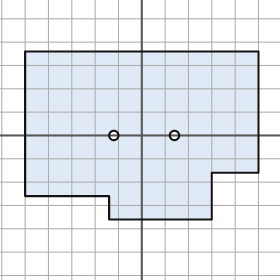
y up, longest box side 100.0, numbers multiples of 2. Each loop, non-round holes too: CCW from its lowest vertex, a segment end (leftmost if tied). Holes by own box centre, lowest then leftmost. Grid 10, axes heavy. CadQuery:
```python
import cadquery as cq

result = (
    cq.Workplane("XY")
    .moveTo(-14.0, -36.0)
    .lineTo(30.0, -36.0)
    .lineTo(30.0, -16.0)
    .lineTo(50.0, -16.0)
    .lineTo(50.0, 36.0)
    .lineTo(-50.0, 36.0)
    .lineTo(-50.0, -26.0)
    .lineTo(-14.0, -26.0)
    .close()
    .moveTo(-12.0, 0.0)
    .circle(2.0)
    .moveTo(14.0, 0.0)
    .circle(2.0)
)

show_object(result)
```